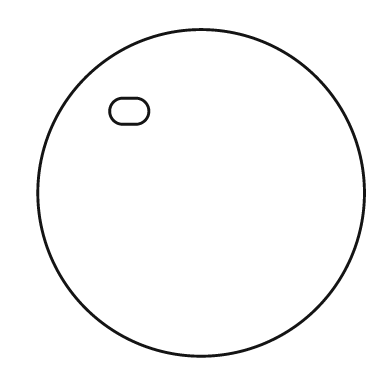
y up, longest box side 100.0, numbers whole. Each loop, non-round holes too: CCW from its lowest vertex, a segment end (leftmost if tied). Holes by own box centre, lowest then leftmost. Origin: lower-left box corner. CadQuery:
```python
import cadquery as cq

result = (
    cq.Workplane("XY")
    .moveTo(50.0, 50.0)
    .circle(50.0)
    .moveTo(26.0, 71.0)
    .lineTo(30.0, 71.0)
    .threePointArc((34.0, 75.0), (30.0, 79.0))
    .lineTo(26.0, 79.0)
    .threePointArc((22.0, 75.0), (26.0, 71.0))
    .close()
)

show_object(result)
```